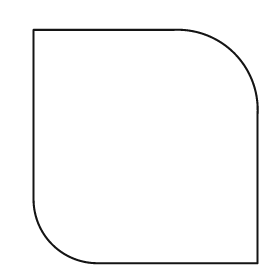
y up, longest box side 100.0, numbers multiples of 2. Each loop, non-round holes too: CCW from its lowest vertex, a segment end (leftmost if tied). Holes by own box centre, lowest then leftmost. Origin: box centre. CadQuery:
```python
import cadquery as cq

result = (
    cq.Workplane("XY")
    .moveTo(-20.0, -50.0)
    .lineTo(48.0, -50.0)
    .lineTo(48.0, 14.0)
    .threePointArc((38.0, 40.0), (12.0, 50.0))
    .lineTo(-48.0, 50.0)
    .lineTo(-48.0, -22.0)
    .threePointArc((-40.0, -42.0), (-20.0, -50.0))
    .close()
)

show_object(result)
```